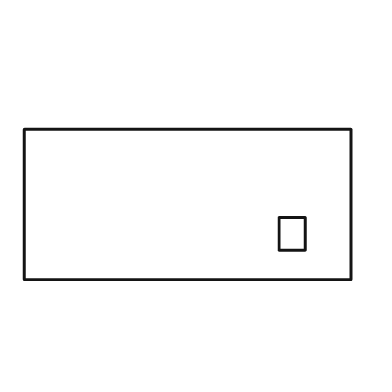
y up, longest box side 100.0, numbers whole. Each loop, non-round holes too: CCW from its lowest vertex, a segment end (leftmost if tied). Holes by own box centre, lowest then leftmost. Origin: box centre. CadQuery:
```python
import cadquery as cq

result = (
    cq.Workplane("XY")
    .moveTo(-50.0, -23.0)
    .lineTo(50.0, -23.0)
    .lineTo(50.0, 23.0)
    .lineTo(-50.0, 23.0)
    .close()
    .moveTo(28.0, -14.0)
    .lineTo(36.0, -14.0)
    .lineTo(36.0, -4.0)
    .lineTo(28.0, -4.0)
    .close()
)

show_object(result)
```